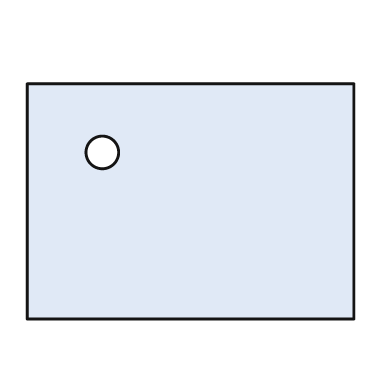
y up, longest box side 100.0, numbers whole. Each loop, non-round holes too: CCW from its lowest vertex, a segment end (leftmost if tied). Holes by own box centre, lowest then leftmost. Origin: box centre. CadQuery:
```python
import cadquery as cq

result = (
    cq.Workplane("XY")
    .moveTo(-50.0, -36.0)
    .lineTo(50.0, -36.0)
    .lineTo(50.0, 36.0)
    .lineTo(-50.0, 36.0)
    .close()
    .moveTo(-27.0, 15.0)
    .circle(5.0)
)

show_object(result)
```